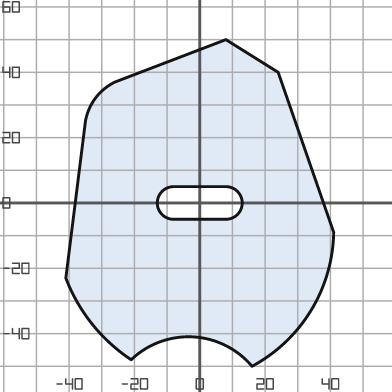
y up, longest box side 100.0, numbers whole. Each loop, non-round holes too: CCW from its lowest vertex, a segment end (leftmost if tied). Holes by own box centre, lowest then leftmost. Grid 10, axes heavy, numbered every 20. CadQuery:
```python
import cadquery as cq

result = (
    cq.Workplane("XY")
    .moveTo(16.0, -50.0)
    .threePointArc((34.0, -33.0), (41.0, -9.0))
    .lineTo(24.0, 40.0)
    .lineTo(8.0, 50.0)
    .lineTo(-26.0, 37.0)
    .threePointArc((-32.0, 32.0), (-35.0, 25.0))
    .lineTo(-41.0, -23.0)
    .threePointArc((-33.0, -37.0), (-21.0, -48.0))
    .threePointArc((-2.0, -41.0), (16.0, -50.0))
    .close()
    .moveTo(-8.0, -5.0)
    .lineTo(8.0, -5.0)
    .threePointArc((13.0, 0.0), (8.0, 5.0))
    .lineTo(-8.0, 5.0)
    .threePointArc((-13.0, 0.0), (-8.0, -5.0))
    .close()
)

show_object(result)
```